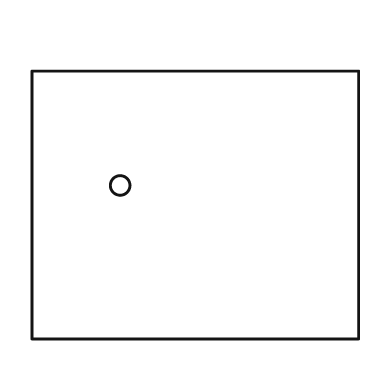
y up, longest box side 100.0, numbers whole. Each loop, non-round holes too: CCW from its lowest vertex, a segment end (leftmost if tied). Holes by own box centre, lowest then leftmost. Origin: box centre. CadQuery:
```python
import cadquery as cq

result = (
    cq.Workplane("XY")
    .moveTo(-50.0, -41.0)
    .lineTo(50.0, -41.0)
    .lineTo(50.0, 41.0)
    .lineTo(-50.0, 41.0)
    .close()
    .moveTo(-23.0, 6.0)
    .circle(3.0)
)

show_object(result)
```